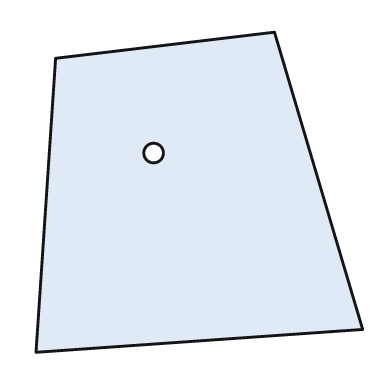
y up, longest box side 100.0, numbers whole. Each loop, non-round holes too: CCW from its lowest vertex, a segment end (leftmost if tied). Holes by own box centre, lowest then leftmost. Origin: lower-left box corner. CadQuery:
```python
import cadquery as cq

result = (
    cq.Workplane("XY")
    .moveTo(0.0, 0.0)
    .lineTo(100.0, 7.0)
    .lineTo(73.0, 98.0)
    .lineTo(6.0, 90.0)
    .close()
    .moveTo(36.0, 61.0)
    .circle(3.0)
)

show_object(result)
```